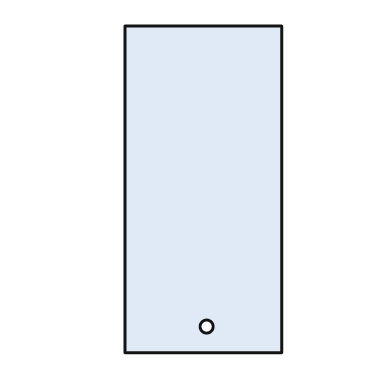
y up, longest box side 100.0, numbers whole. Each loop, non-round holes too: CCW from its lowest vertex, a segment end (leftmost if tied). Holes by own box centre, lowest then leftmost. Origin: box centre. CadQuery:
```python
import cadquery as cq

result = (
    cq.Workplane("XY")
    .moveTo(-24.0, -50.0)
    .lineTo(24.0, -50.0)
    .lineTo(24.0, 50.0)
    .lineTo(-24.0, 50.0)
    .close()
    .moveTo(1.0, -42.0)
    .circle(2.0)
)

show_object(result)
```